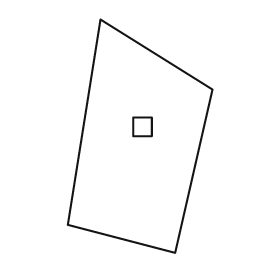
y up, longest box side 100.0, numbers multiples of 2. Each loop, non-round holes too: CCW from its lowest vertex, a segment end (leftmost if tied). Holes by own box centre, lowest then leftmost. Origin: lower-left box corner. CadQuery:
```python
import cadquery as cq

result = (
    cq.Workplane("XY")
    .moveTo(46.0, 0.0)
    .lineTo(62.0, 70.0)
    .lineTo(14.0, 100.0)
    .lineTo(0.0, 12.0)
    .close()
    .moveTo(28.0, 50.0)
    .lineTo(36.0, 50.0)
    .lineTo(36.0, 58.0)
    .lineTo(28.0, 58.0)
    .close()
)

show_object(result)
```